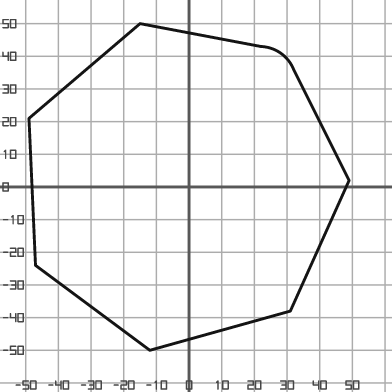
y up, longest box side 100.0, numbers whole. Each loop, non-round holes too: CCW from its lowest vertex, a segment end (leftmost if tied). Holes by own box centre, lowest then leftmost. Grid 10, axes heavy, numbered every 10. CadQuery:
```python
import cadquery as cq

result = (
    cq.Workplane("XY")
    .moveTo(-12.0, -50.0)
    .lineTo(31.0, -38.0)
    .lineTo(49.0, 2.0)
    .lineTo(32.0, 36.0)
    .threePointArc((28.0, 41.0), (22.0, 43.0))
    .lineTo(-15.0, 50.0)
    .lineTo(-49.0, 21.0)
    .lineTo(-47.0, -24.0)
    .close()
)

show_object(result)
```